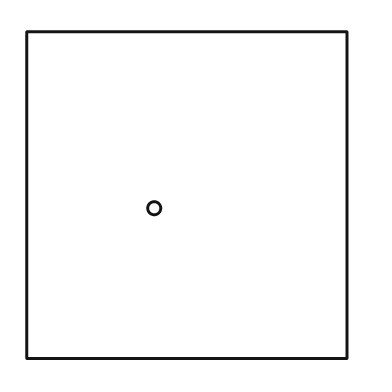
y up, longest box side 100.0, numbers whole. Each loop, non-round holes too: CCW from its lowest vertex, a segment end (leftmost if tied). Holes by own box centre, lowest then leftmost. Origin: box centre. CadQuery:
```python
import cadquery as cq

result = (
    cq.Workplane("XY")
    .moveTo(-49.0, -50.0)
    .lineTo(49.0, -50.0)
    .lineTo(49.0, 50.0)
    .lineTo(-49.0, 50.0)
    .close()
    .moveTo(-10.0, -4.0)
    .circle(2.0)
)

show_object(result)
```